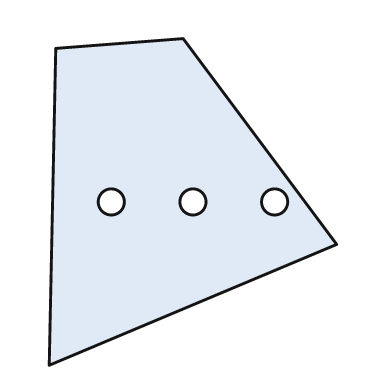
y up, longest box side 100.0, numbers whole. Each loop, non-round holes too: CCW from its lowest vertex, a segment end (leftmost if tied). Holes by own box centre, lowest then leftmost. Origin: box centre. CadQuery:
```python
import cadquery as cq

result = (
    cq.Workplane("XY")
    .moveTo(-44.0, -50.0)
    .lineTo(44.0, -13.0)
    .lineTo(-3.0, 50.0)
    .lineTo(-42.0, 47.0)
    .close()
    .moveTo(-25.0, 0.0)
    .circle(4.0)
    .moveTo(0.0, 0.0)
    .circle(4.0)
    .moveTo(25.0, 0.0)
    .circle(4.0)
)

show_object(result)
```